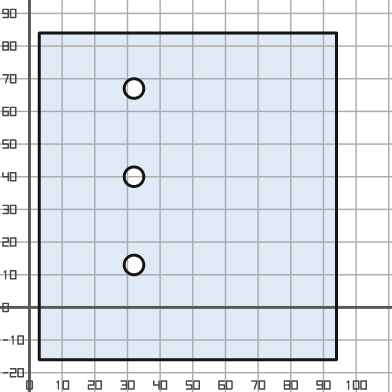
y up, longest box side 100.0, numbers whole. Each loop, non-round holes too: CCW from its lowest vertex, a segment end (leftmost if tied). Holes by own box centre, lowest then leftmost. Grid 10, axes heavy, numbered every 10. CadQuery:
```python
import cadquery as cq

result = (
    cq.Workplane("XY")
    .moveTo(3.0, -16.0)
    .lineTo(94.0, -16.0)
    .lineTo(94.0, 84.0)
    .lineTo(3.0, 84.0)
    .close()
    .moveTo(32.0, 13.0)
    .circle(3.0)
    .moveTo(32.0, 40.0)
    .circle(3.0)
    .moveTo(32.0, 67.0)
    .circle(3.0)
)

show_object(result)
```